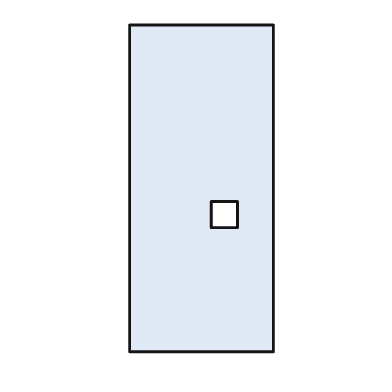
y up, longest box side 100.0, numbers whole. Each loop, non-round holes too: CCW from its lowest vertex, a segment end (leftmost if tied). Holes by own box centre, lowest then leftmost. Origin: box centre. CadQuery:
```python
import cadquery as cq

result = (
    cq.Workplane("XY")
    .moveTo(-22.0, -50.0)
    .lineTo(22.0, -50.0)
    .lineTo(22.0, 50.0)
    .lineTo(-22.0, 50.0)
    .close()
    .moveTo(3.0, -12.0)
    .lineTo(11.0, -12.0)
    .lineTo(11.0, -4.0)
    .lineTo(3.0, -4.0)
    .close()
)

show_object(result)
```